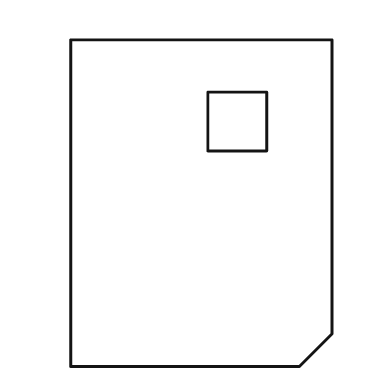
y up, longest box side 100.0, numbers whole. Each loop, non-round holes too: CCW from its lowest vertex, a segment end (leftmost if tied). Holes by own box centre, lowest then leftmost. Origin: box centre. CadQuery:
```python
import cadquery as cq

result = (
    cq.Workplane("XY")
    .moveTo(-40.0, -50.0)
    .lineTo(30.0, -50.0)
    .lineTo(40.0, -40.0)
    .lineTo(40.0, 50.0)
    .lineTo(-40.0, 50.0)
    .close()
    .moveTo(2.0, 16.0)
    .lineTo(20.0, 16.0)
    .lineTo(20.0, 34.0)
    .lineTo(2.0, 34.0)
    .close()
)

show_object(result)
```